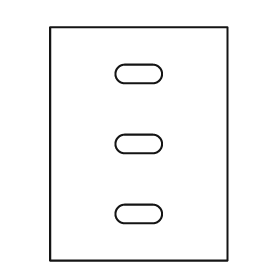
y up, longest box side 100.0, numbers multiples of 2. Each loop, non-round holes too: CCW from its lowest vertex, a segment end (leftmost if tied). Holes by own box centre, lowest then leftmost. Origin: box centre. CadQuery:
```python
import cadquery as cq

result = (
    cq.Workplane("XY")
    .moveTo(-38.0, -50.0)
    .lineTo(38.0, -50.0)
    .lineTo(38.0, 50.0)
    .lineTo(-38.0, 50.0)
    .close()
    .moveTo(-6.0, -34.0)
    .lineTo(6.0, -34.0)
    .threePointArc((10.0, -30.0), (6.0, -26.0))
    .lineTo(-6.0, -26.0)
    .threePointArc((-10.0, -30.0), (-6.0, -34.0))
    .close()
    .moveTo(-6.0, -4.0)
    .lineTo(6.0, -4.0)
    .threePointArc((10.0, 0.0), (6.0, 4.0))
    .lineTo(-6.0, 4.0)
    .threePointArc((-10.0, 0.0), (-6.0, -4.0))
    .close()
    .moveTo(-6.0, 26.0)
    .lineTo(6.0, 26.0)
    .threePointArc((10.0, 30.0), (6.0, 34.0))
    .lineTo(-6.0, 34.0)
    .threePointArc((-10.0, 30.0), (-6.0, 26.0))
    .close()
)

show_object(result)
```